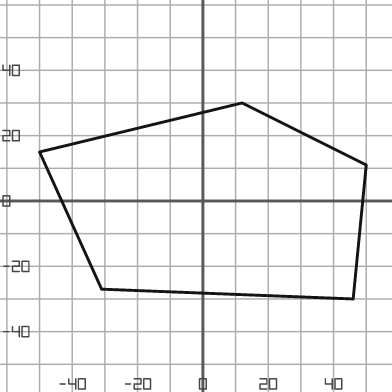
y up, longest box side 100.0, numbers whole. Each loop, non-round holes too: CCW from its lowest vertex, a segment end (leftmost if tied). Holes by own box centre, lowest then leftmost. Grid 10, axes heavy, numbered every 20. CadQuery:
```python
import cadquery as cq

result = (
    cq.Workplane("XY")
    .moveTo(46.0, -30.0)
    .lineTo(50.0, 11.0)
    .lineTo(12.0, 30.0)
    .lineTo(-50.0, 15.0)
    .lineTo(-31.0, -27.0)
    .close()
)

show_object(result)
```